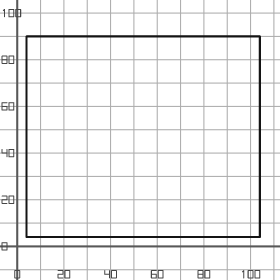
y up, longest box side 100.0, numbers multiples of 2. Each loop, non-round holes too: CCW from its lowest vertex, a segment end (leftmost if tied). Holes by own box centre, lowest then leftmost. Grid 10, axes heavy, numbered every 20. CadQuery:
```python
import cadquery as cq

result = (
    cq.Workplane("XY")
    .moveTo(4.0, 4.0)
    .lineTo(104.0, 4.0)
    .lineTo(104.0, 90.0)
    .lineTo(4.0, 90.0)
    .close()
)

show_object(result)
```